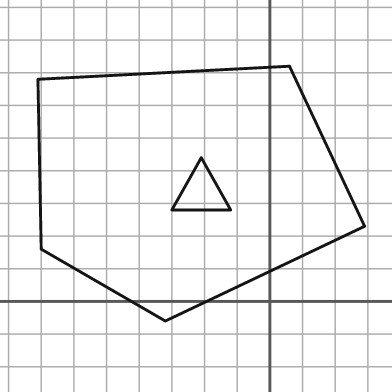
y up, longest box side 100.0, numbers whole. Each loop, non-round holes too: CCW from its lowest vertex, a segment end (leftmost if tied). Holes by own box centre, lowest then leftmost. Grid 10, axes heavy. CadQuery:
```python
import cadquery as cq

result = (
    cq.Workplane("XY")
    .moveTo(-32.0, -6.0)
    .lineTo(29.0, 23.0)
    .lineTo(6.0, 72.0)
    .lineTo(-71.0, 68.0)
    .lineTo(-70.0, 16.0)
    .close()
    .moveTo(-30.0, 28.0)
    .lineTo(-12.0, 28.0)
    .lineTo(-21.0, 44.0)
    .close()
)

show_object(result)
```